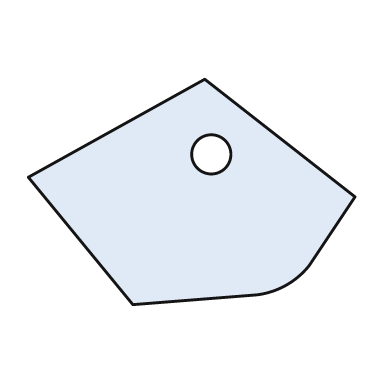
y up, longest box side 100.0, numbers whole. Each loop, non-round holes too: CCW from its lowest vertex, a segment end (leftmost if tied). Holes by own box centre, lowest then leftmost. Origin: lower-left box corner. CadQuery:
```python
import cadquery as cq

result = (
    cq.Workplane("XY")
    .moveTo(32.0, 0.0)
    .lineTo(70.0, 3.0)
    .threePointArc((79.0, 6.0), (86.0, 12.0))
    .lineTo(100.0, 33.0)
    .lineTo(54.0, 69.0)
    .lineTo(0.0, 39.0)
    .close()
    .moveTo(56.0, 46.0)
    .circle(6.0)
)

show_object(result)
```